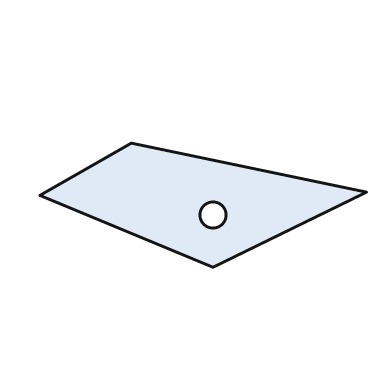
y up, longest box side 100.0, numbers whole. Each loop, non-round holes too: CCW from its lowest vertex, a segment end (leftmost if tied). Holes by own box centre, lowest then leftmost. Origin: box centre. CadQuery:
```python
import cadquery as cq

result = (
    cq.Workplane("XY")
    .moveTo(3.0, -19.0)
    .lineTo(50.0, 4.0)
    .lineTo(-22.0, 19.0)
    .lineTo(-50.0, 3.0)
    .close()
    .moveTo(3.0, -3.0)
    .circle(4.0)
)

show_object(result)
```